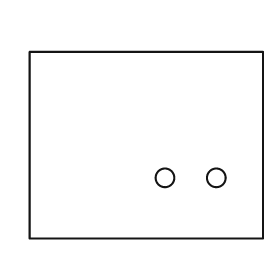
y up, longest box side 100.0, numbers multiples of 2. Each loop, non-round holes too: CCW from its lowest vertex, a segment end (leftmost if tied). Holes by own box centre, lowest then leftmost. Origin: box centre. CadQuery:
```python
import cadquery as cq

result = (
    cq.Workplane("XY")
    .moveTo(-50.0, -40.0)
    .lineTo(50.0, -40.0)
    .lineTo(50.0, 40.0)
    .lineTo(-50.0, 40.0)
    .close()
    .moveTo(8.0, -14.0)
    .circle(4.0)
    .moveTo(30.0, -14.0)
    .circle(4.0)
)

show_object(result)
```